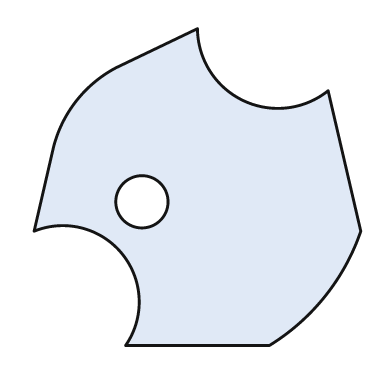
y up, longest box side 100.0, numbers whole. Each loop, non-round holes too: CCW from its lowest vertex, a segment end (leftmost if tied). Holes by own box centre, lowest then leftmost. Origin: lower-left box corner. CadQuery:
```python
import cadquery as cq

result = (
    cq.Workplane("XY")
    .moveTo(28.0, 0.0)
    .lineTo(72.0, 0.0)
    .threePointArc((89.0, 15.0), (100.0, 35.0))
    .lineTo(90.0, 78.0)
    .threePointArc((64.0, 75.0), (50.0, 97.0))
    .lineTo(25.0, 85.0)
    .threePointArc((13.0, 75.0), (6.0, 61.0))
    .lineTo(0.0, 35.0)
    .threePointArc((27.0, 28.0), (28.0, 0.0))
    .close()
    .moveTo(33.0, 44.0)
    .circle(8.0)
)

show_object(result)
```